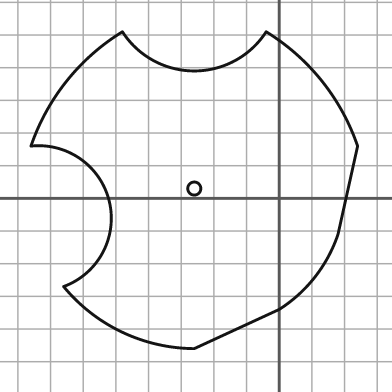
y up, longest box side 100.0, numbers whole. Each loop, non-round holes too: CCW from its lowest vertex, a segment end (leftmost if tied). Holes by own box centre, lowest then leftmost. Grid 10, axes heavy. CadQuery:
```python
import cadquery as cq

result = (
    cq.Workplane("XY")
    .moveTo(-26.0, -46.0)
    .lineTo(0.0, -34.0)
    .threePointArc((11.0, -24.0), (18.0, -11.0))
    .lineTo(24.0, 16.0)
    .threePointArc((13.0, 36.0), (-4.0, 51.0))
    .threePointArc((-26.0, 39.0), (-48.0, 51.0))
    .threePointArc((-65.0, 36.0), (-76.0, 16.0))
    .threePointArc((-52.0, -1.0), (-66.0, -27.0))
    .threePointArc((-48.0, -41.0), (-26.0, -46.0))
    .close()
    .moveTo(-26.0, 3.0)
    .circle(2.0)
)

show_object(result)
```